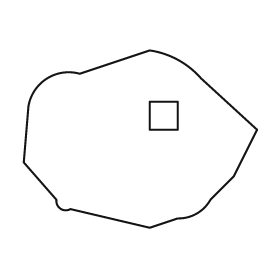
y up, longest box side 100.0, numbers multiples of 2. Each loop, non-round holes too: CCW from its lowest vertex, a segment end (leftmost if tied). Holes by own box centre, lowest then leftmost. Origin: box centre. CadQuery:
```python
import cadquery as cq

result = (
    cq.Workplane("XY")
    .moveTo(4.0, -38.0)
    .lineTo(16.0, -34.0)
    .threePointArc((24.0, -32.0), (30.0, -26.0))
    .lineTo(40.0, -16.0)
    .lineTo(50.0, 4.0)
    .lineTo(26.0, 26.0)
    .threePointArc((16.0, 34.0), (4.0, 38.0))
    .lineTo(-26.0, 28.0)
    .threePointArc((-40.0, 26.0), (-48.0, 14.0))
    .lineTo(-50.0, -10.0)
    .lineTo(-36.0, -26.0)
    .threePointArc((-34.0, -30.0), (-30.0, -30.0))
    .close()
    .moveTo(4.0, 4.0)
    .lineTo(16.0, 4.0)
    .lineTo(16.0, 16.0)
    .lineTo(4.0, 16.0)
    .close()
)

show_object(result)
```